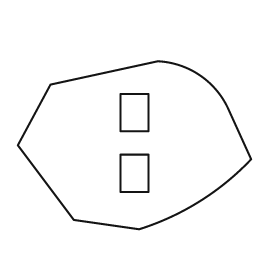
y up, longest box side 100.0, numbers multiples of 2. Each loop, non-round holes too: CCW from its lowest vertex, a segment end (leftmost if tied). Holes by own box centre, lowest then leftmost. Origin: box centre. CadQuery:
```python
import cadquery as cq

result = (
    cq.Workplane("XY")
    .moveTo(2.0, -36.0)
    .threePointArc((28.0, -24.0), (50.0, -6.0))
    .lineTo(40.0, 16.0)
    .threePointArc((28.0, 30.0), (10.0, 36.0))
    .lineTo(-36.0, 26.0)
    .lineTo(-50.0, 0.0)
    .lineTo(-26.0, -32.0)
    .close()
    .moveTo(-6.0, -20.0)
    .lineTo(6.0, -20.0)
    .lineTo(6.0, -4.0)
    .lineTo(-6.0, -4.0)
    .close()
    .moveTo(-6.0, 6.0)
    .lineTo(6.0, 6.0)
    .lineTo(6.0, 22.0)
    .lineTo(-6.0, 22.0)
    .close()
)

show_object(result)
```